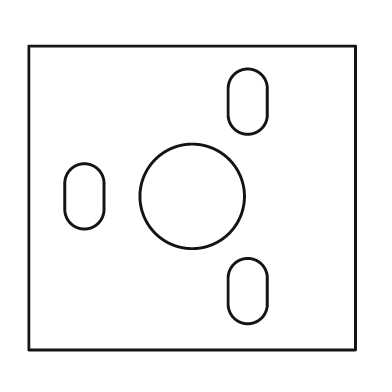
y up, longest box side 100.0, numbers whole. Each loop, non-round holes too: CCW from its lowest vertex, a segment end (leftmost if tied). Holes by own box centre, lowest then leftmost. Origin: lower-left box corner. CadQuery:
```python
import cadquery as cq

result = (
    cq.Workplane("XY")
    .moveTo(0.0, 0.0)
    .lineTo(100.0, 0.0)
    .lineTo(100.0, 93.0)
    .lineTo(0.0, 93.0)
    .close()
    .moveTo(61.0, 14.0)
    .threePointArc((67.0, 8.0), (73.0, 14.0))
    .lineTo(73.0, 22.0)
    .threePointArc((67.0, 28.0), (61.0, 22.0))
    .close()
    .moveTo(11.0, 43.0)
    .threePointArc((17.0, 37.0), (23.0, 43.0))
    .lineTo(23.0, 51.0)
    .threePointArc((17.0, 57.0), (11.0, 51.0))
    .close()
    .moveTo(50.0, 47.0)
    .circle(16.0)
    .moveTo(61.0, 72.0)
    .threePointArc((67.0, 66.0), (73.0, 72.0))
    .lineTo(73.0, 80.0)
    .threePointArc((67.0, 86.0), (61.0, 80.0))
    .close()
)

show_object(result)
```